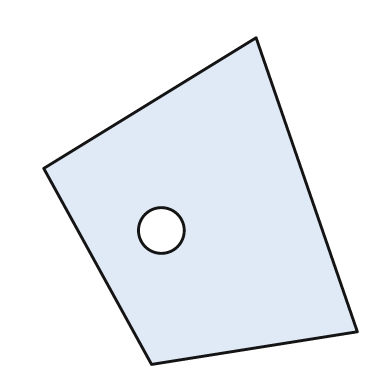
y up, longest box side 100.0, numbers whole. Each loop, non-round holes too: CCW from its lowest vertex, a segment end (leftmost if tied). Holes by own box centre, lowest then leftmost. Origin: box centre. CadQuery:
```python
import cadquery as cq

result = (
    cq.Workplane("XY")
    .moveTo(-15.0, -50.0)
    .lineTo(48.0, -40.0)
    .lineTo(17.0, 50.0)
    .lineTo(-48.0, 10.0)
    .close()
    .moveTo(-12.0, -9.0)
    .circle(7.0)
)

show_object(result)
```